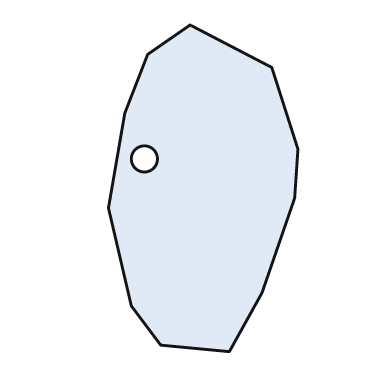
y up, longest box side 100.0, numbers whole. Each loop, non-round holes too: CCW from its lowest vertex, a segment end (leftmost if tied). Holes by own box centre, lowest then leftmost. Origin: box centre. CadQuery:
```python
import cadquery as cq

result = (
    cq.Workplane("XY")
    .moveTo(8.0, -50.0)
    .lineTo(18.0, -32.0)
    .lineTo(28.0, -3.0)
    .lineTo(29.0, 12.0)
    .lineTo(21.0, 37.0)
    .lineTo(-4.0, 50.0)
    .lineTo(-17.0, 41.0)
    .lineTo(-24.0, 23.0)
    .lineTo(-29.0, -6.0)
    .lineTo(-22.0, -36.0)
    .lineTo(-13.0, -48.0)
    .close()
    .moveTo(-18.0, 9.0)
    .circle(4.0)
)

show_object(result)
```